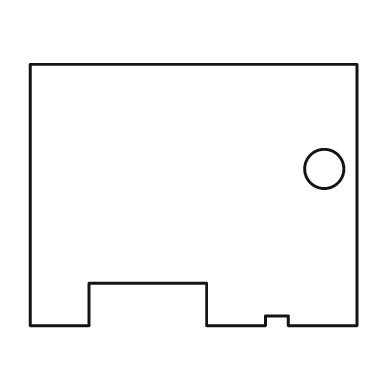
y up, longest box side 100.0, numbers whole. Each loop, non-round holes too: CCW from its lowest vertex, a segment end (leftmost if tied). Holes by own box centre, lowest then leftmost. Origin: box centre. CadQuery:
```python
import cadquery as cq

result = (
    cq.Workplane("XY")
    .moveTo(-50.0, -40.0)
    .lineTo(-32.0, -40.0)
    .lineTo(-32.0, -27.0)
    .lineTo(4.0, -27.0)
    .lineTo(4.0, -40.0)
    .lineTo(22.0, -40.0)
    .lineTo(22.0, -37.0)
    .lineTo(29.0, -37.0)
    .lineTo(29.0, -40.0)
    .lineTo(50.0, -40.0)
    .lineTo(50.0, 40.0)
    .lineTo(-50.0, 40.0)
    .close()
    .moveTo(40.0, 8.0)
    .circle(6.0)
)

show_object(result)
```